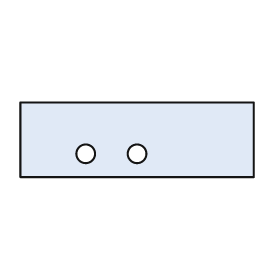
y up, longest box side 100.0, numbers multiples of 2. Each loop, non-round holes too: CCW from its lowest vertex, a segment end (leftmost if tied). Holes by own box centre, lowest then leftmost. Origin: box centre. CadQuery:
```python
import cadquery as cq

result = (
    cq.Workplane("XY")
    .moveTo(-50.0, -16.0)
    .lineTo(50.0, -16.0)
    .lineTo(50.0, 16.0)
    .lineTo(-50.0, 16.0)
    .close()
    .moveTo(-22.0, -6.0)
    .circle(4.0)
    .moveTo(0.0, -6.0)
    .circle(4.0)
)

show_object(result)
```